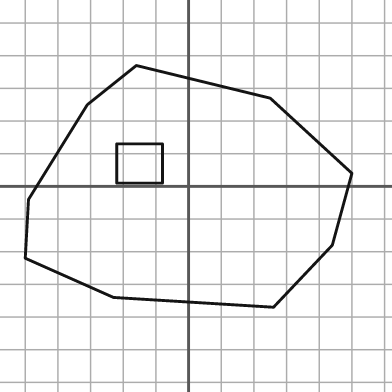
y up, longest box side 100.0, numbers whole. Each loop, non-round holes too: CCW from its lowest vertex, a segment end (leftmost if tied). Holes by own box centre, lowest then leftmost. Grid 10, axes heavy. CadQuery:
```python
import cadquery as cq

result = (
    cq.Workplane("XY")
    .moveTo(26.0, -37.0)
    .lineTo(44.0, -18.0)
    .lineTo(50.0, 4.0)
    .lineTo(25.0, 27.0)
    .lineTo(-16.0, 37.0)
    .lineTo(-31.0, 25.0)
    .lineTo(-49.0, -4.0)
    .lineTo(-50.0, -22.0)
    .lineTo(-23.0, -34.0)
    .close()
    .moveTo(-22.0, 1.0)
    .lineTo(-8.0, 1.0)
    .lineTo(-8.0, 13.0)
    .lineTo(-22.0, 13.0)
    .close()
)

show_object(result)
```